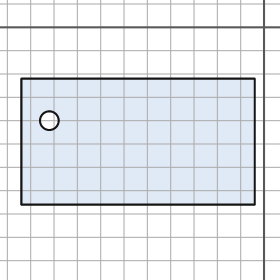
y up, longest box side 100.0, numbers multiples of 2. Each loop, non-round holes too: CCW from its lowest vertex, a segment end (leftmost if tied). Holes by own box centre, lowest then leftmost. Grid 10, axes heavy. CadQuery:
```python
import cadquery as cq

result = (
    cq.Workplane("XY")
    .moveTo(-104.0, -76.0)
    .lineTo(-4.0, -76.0)
    .lineTo(-4.0, -22.0)
    .lineTo(-104.0, -22.0)
    .close()
    .moveTo(-92.0, -40.0)
    .circle(4.0)
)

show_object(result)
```